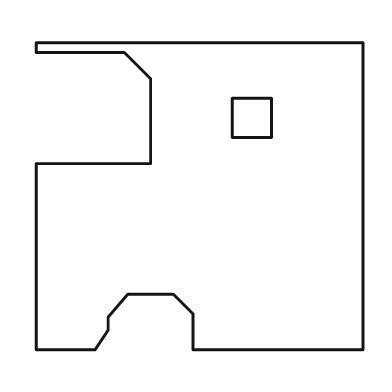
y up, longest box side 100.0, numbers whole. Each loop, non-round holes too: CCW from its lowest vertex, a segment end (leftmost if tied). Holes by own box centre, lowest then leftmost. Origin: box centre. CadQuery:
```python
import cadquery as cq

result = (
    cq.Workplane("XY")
    .moveTo(-50.0, -47.0)
    .lineTo(-32.0, -47.0)
    .lineTo(-28.0, -41.0)
    .lineTo(-28.0, -37.0)
    .lineTo(-22.0, -30.0)
    .lineTo(-8.0, -30.0)
    .lineTo(-2.0, -36.0)
    .lineTo(-2.0, -47.0)
    .lineTo(50.0, -47.0)
    .lineTo(50.0, 47.0)
    .lineTo(-50.0, 47.0)
    .lineTo(-50.0, 44.0)
    .lineTo(-23.0, 44.0)
    .lineTo(-15.0, 36.0)
    .lineTo(-15.0, 10.0)
    .lineTo(-50.0, 10.0)
    .close()
    .moveTo(10.0, 18.0)
    .lineTo(22.0, 18.0)
    .lineTo(22.0, 30.0)
    .lineTo(10.0, 30.0)
    .close()
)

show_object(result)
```